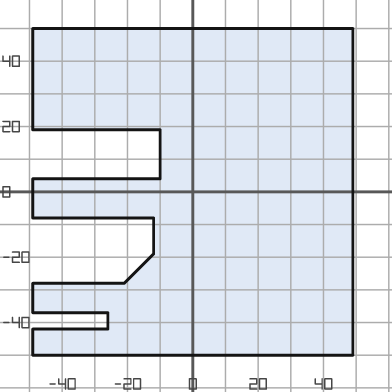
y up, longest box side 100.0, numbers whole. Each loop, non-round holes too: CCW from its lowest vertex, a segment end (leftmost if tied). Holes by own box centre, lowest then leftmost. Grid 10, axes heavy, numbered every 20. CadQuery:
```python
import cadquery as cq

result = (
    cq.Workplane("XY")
    .moveTo(-49.0, -50.0)
    .lineTo(49.0, -50.0)
    .lineTo(49.0, 50.0)
    .lineTo(-49.0, 50.0)
    .lineTo(-49.0, 19.0)
    .lineTo(-10.0, 19.0)
    .lineTo(-10.0, 4.0)
    .lineTo(-49.0, 4.0)
    .lineTo(-49.0, -8.0)
    .lineTo(-12.0, -8.0)
    .lineTo(-12.0, -19.0)
    .lineTo(-21.0, -28.0)
    .lineTo(-49.0, -28.0)
    .lineTo(-49.0, -37.0)
    .lineTo(-26.0, -37.0)
    .lineTo(-26.0, -42.0)
    .lineTo(-49.0, -42.0)
    .close()
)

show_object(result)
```